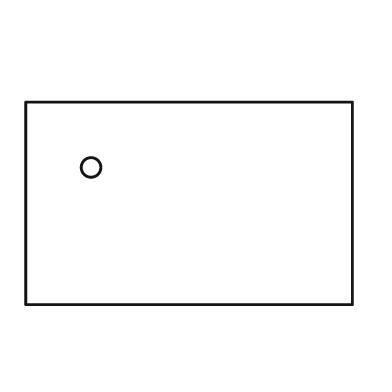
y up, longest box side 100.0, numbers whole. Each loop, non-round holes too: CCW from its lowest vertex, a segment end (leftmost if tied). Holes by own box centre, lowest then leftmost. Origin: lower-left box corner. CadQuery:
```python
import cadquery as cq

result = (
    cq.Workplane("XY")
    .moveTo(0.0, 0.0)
    .lineTo(100.0, 0.0)
    .lineTo(100.0, 62.0)
    .lineTo(0.0, 62.0)
    .close()
    .moveTo(20.0, 42.0)
    .circle(3.0)
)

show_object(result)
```